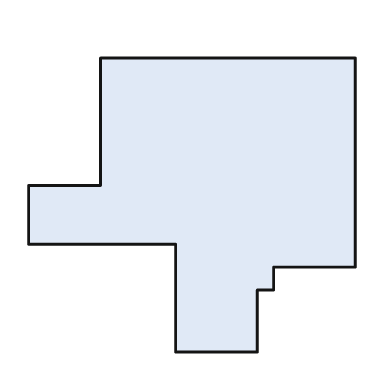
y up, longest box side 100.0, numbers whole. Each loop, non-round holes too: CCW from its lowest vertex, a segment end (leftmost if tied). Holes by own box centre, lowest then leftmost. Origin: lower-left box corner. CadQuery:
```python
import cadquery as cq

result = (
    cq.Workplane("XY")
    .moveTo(45.0, 0.0)
    .lineTo(70.0, 0.0)
    .lineTo(70.0, 19.0)
    .lineTo(75.0, 19.0)
    .lineTo(75.0, 26.0)
    .lineTo(100.0, 26.0)
    .lineTo(100.0, 90.0)
    .lineTo(22.0, 90.0)
    .lineTo(22.0, 51.0)
    .lineTo(0.0, 51.0)
    .lineTo(0.0, 33.0)
    .lineTo(45.0, 33.0)
    .close()
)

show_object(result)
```